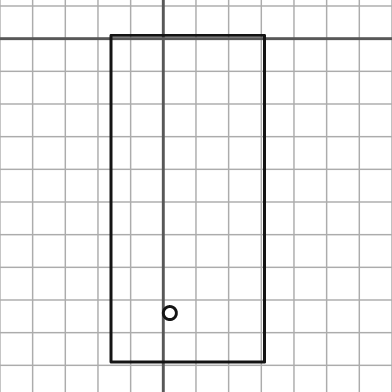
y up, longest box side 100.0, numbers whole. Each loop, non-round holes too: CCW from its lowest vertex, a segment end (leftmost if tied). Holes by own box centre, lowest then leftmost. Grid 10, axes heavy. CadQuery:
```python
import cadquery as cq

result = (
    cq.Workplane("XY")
    .moveTo(-16.0, -99.0)
    .lineTo(31.0, -99.0)
    .lineTo(31.0, 1.0)
    .lineTo(-16.0, 1.0)
    .close()
    .moveTo(2.0, -84.0)
    .circle(2.0)
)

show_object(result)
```